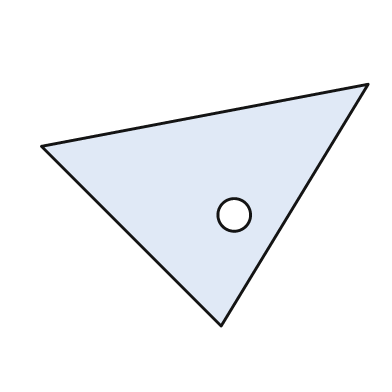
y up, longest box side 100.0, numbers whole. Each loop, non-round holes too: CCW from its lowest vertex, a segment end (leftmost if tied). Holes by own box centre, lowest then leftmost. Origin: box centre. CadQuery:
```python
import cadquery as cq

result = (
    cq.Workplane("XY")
    .moveTo(5.0, -37.0)
    .lineTo(50.0, 37.0)
    .lineTo(-50.0, 18.0)
    .close()
    .moveTo(9.0, -3.0)
    .circle(5.0)
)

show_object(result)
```